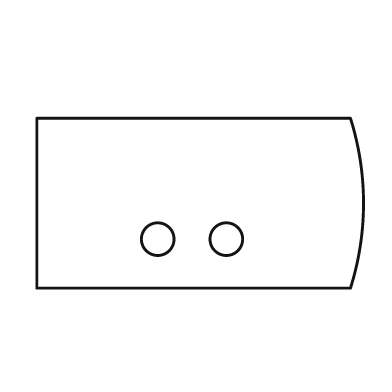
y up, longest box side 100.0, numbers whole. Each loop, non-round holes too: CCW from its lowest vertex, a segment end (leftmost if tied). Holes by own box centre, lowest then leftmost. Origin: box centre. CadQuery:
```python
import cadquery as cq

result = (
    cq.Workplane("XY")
    .moveTo(-50.0, -26.0)
    .lineTo(46.0, -26.0)
    .threePointArc((50.0, 0.0), (46.0, 26.0))
    .lineTo(-50.0, 26.0)
    .close()
    .moveTo(-13.0, -11.0)
    .circle(5.0)
    .moveTo(8.0, -11.0)
    .circle(5.0)
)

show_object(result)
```